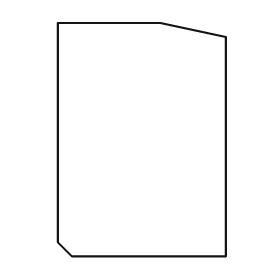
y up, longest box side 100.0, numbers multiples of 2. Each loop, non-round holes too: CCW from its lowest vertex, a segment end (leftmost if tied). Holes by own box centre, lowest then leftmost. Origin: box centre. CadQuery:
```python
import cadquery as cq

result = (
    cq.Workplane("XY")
    .moveTo(-30.0, -50.0)
    .lineTo(36.0, -50.0)
    .lineTo(36.0, 44.0)
    .lineTo(8.0, 50.0)
    .lineTo(-36.0, 50.0)
    .lineTo(-36.0, -44.0)
    .close()
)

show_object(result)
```